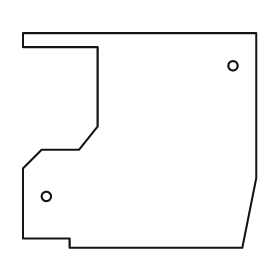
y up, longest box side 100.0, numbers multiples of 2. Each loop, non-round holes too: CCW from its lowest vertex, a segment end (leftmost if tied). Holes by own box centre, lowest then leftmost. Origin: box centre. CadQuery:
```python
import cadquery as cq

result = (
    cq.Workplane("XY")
    .moveTo(-30.0, -46.0)
    .lineTo(44.0, -46.0)
    .lineTo(50.0, -16.0)
    .lineTo(50.0, 46.0)
    .lineTo(-50.0, 46.0)
    .lineTo(-50.0, 40.0)
    .lineTo(-18.0, 40.0)
    .lineTo(-18.0, 6.0)
    .lineTo(-26.0, -4.0)
    .lineTo(-42.0, -4.0)
    .lineTo(-50.0, -12.0)
    .lineTo(-50.0, -42.0)
    .lineTo(-30.0, -42.0)
    .close()
    .moveTo(-40.0, -24.0)
    .circle(2.0)
    .moveTo(40.0, 32.0)
    .circle(2.0)
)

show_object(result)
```